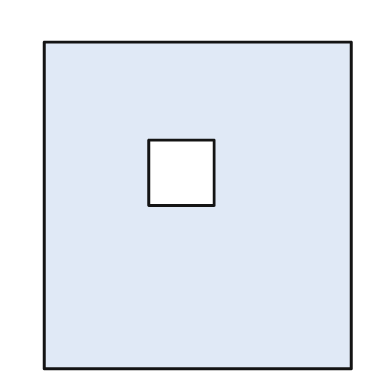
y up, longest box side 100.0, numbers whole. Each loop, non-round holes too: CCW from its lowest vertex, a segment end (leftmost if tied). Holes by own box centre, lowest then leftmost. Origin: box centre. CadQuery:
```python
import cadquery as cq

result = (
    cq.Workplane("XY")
    .moveTo(-47.0, -50.0)
    .lineTo(47.0, -50.0)
    .lineTo(47.0, 50.0)
    .lineTo(-47.0, 50.0)
    .close()
    .moveTo(-15.0, 0.0)
    .lineTo(5.0, 0.0)
    .lineTo(5.0, 20.0)
    .lineTo(-15.0, 20.0)
    .close()
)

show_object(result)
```